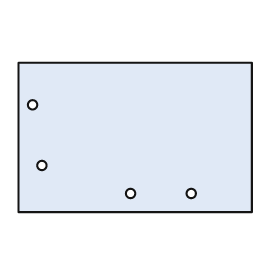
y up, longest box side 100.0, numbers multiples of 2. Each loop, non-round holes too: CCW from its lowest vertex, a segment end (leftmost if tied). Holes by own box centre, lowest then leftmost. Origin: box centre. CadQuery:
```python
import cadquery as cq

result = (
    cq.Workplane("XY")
    .moveTo(-50.0, -32.0)
    .lineTo(50.0, -32.0)
    .lineTo(50.0, 32.0)
    .lineTo(-50.0, 32.0)
    .close()
    .moveTo(-2.0, -24.0)
    .circle(2.0)
    .moveTo(24.0, -24.0)
    .circle(2.0)
    .moveTo(-40.0, -12.0)
    .circle(2.0)
    .moveTo(-44.0, 14.0)
    .circle(2.0)
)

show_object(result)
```